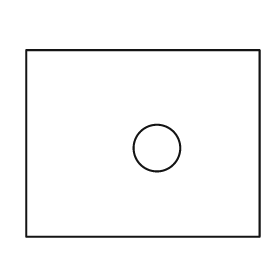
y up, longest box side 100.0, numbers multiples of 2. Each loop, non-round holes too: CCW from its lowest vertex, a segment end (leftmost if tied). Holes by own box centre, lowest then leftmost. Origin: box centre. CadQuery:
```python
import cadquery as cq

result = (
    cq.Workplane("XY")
    .moveTo(-50.0, -40.0)
    .lineTo(50.0, -40.0)
    .lineTo(50.0, 40.0)
    .lineTo(-50.0, 40.0)
    .close()
    .moveTo(6.0, -2.0)
    .circle(10.0)
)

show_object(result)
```